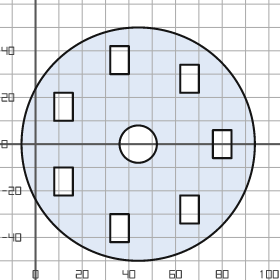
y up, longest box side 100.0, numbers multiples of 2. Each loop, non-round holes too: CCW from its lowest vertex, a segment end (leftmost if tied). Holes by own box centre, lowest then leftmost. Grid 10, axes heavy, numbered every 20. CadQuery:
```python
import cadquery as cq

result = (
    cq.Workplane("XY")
    .moveTo(44.0, 0.0)
    .circle(50.0)
    .moveTo(32.0, -42.0)
    .lineTo(40.0, -42.0)
    .lineTo(40.0, -30.0)
    .lineTo(32.0, -30.0)
    .close()
    .moveTo(62.0, -34.0)
    .lineTo(70.0, -34.0)
    .lineTo(70.0, -22.0)
    .lineTo(62.0, -22.0)
    .close()
    .moveTo(8.0, -22.0)
    .lineTo(16.0, -22.0)
    .lineTo(16.0, -10.0)
    .lineTo(8.0, -10.0)
    .close()
    .moveTo(44.0, 0.0)
    .circle(8.0)
    .moveTo(76.0, -6.0)
    .lineTo(84.0, -6.0)
    .lineTo(84.0, 6.0)
    .lineTo(76.0, 6.0)
    .close()
    .moveTo(8.0, 10.0)
    .lineTo(16.0, 10.0)
    .lineTo(16.0, 22.0)
    .lineTo(8.0, 22.0)
    .close()
    .moveTo(62.0, 22.0)
    .lineTo(70.0, 22.0)
    .lineTo(70.0, 34.0)
    .lineTo(62.0, 34.0)
    .close()
    .moveTo(32.0, 30.0)
    .lineTo(40.0, 30.0)
    .lineTo(40.0, 42.0)
    .lineTo(32.0, 42.0)
    .close()
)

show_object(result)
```